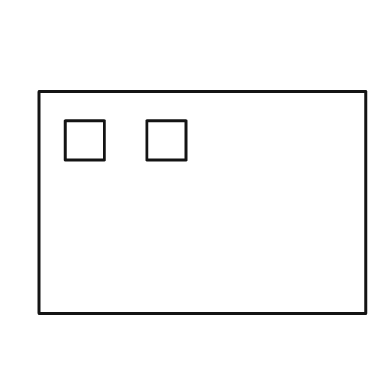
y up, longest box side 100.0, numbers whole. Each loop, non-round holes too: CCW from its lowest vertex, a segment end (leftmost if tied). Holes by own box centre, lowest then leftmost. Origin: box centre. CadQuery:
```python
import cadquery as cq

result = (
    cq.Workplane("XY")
    .moveTo(-50.0, -34.0)
    .lineTo(50.0, -34.0)
    .lineTo(50.0, 34.0)
    .lineTo(-50.0, 34.0)
    .close()
    .moveTo(-42.0, 13.0)
    .lineTo(-30.0, 13.0)
    .lineTo(-30.0, 25.0)
    .lineTo(-42.0, 25.0)
    .close()
    .moveTo(-17.0, 13.0)
    .lineTo(-5.0, 13.0)
    .lineTo(-5.0, 25.0)
    .lineTo(-17.0, 25.0)
    .close()
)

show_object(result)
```